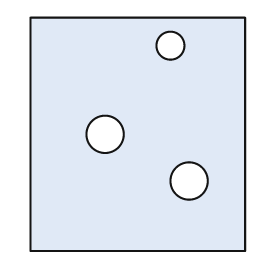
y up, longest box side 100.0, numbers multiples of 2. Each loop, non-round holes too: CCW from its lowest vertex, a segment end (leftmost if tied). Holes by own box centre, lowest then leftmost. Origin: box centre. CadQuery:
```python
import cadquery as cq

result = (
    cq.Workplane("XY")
    .moveTo(-46.0, -50.0)
    .lineTo(46.0, -50.0)
    .lineTo(46.0, 50.0)
    .lineTo(-46.0, 50.0)
    .close()
    .moveTo(22.0, -20.0)
    .circle(8.0)
    .moveTo(-14.0, 0.0)
    .circle(8.0)
    .moveTo(14.0, 38.0)
    .circle(6.0)
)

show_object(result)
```